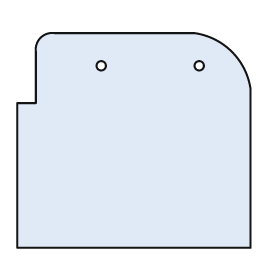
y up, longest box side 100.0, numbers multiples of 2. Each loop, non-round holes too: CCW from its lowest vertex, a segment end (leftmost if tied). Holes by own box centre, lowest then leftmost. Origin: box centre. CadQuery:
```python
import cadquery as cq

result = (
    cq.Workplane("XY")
    .moveTo(-50.0, -46.0)
    .lineTo(50.0, -46.0)
    .lineTo(50.0, 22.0)
    .threePointArc((42.0, 38.0), (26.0, 46.0))
    .lineTo(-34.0, 46.0)
    .threePointArc((-40.0, 44.0), (-42.0, 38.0))
    .lineTo(-42.0, 16.0)
    .lineTo(-50.0, 16.0)
    .close()
    .moveTo(-14.0, 32.0)
    .circle(2.0)
    .moveTo(28.0, 32.0)
    .circle(2.0)
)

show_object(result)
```